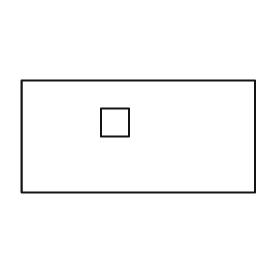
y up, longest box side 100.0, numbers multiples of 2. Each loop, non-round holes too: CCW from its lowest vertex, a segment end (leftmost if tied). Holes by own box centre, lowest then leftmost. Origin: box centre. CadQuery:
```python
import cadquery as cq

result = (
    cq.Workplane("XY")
    .moveTo(-50.0, -24.0)
    .lineTo(50.0, -24.0)
    .lineTo(50.0, 24.0)
    .lineTo(-50.0, 24.0)
    .close()
    .moveTo(-16.0, 0.0)
    .lineTo(-4.0, 0.0)
    .lineTo(-4.0, 12.0)
    .lineTo(-16.0, 12.0)
    .close()
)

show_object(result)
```